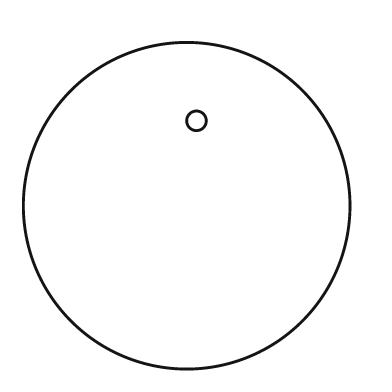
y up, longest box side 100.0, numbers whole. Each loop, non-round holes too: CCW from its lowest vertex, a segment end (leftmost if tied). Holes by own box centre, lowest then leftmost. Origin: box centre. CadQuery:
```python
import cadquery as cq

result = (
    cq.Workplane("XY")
    .moveTo(0.0, 0.0)
    .circle(50.0)
    .moveTo(3.0, 26.0)
    .circle(3.0)
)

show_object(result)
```